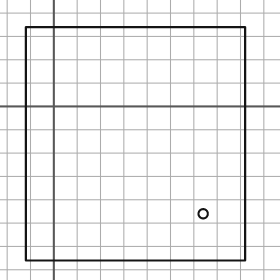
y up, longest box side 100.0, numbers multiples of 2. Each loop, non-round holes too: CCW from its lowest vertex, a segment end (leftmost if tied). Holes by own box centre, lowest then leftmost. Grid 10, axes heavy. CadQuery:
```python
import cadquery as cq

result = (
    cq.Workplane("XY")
    .moveTo(-12.0, -66.0)
    .lineTo(82.0, -66.0)
    .lineTo(82.0, 34.0)
    .lineTo(-12.0, 34.0)
    .close()
    .moveTo(64.0, -46.0)
    .circle(2.0)
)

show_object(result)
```